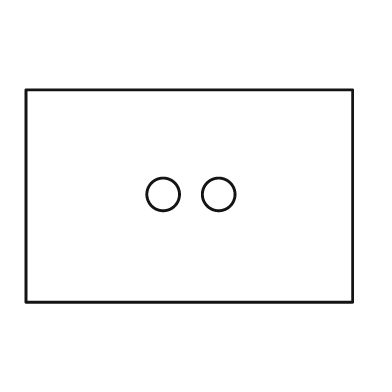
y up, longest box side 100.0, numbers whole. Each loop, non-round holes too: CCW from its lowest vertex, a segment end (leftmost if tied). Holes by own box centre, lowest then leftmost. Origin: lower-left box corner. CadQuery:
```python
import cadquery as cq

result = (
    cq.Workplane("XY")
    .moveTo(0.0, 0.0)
    .lineTo(100.0, 0.0)
    .lineTo(100.0, 65.0)
    .lineTo(0.0, 65.0)
    .close()
    .moveTo(42.0, 33.0)
    .circle(5.0)
    .moveTo(59.0, 33.0)
    .circle(5.0)
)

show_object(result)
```